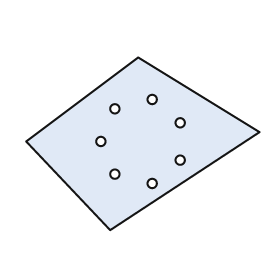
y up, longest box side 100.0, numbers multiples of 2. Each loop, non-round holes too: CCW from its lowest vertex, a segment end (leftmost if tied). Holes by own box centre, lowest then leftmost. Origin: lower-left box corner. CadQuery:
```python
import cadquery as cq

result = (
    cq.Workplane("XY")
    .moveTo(36.0, 0.0)
    .lineTo(100.0, 42.0)
    .lineTo(48.0, 74.0)
    .lineTo(0.0, 38.0)
    .close()
    .moveTo(54.0, 20.0)
    .circle(2.0)
    .moveTo(38.0, 24.0)
    .circle(2.0)
    .moveTo(66.0, 30.0)
    .circle(2.0)
    .moveTo(32.0, 38.0)
    .circle(2.0)
    .moveTo(66.0, 46.0)
    .circle(2.0)
    .moveTo(38.0, 52.0)
    .circle(2.0)
    .moveTo(54.0, 56.0)
    .circle(2.0)
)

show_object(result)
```